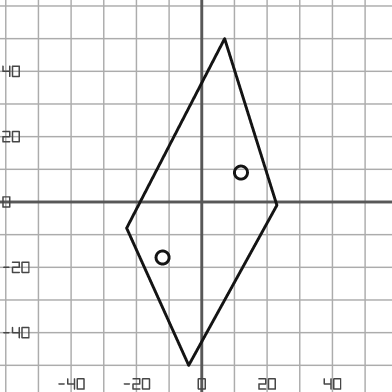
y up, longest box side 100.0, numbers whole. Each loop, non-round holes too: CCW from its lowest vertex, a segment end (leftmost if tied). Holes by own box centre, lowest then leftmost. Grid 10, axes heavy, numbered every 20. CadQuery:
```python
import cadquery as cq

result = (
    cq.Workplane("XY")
    .moveTo(-4.0, -50.0)
    .lineTo(23.0, -1.0)
    .lineTo(7.0, 50.0)
    .lineTo(-23.0, -8.0)
    .close()
    .moveTo(-12.0, -17.0)
    .circle(2.0)
    .moveTo(12.0, 9.0)
    .circle(2.0)
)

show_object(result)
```